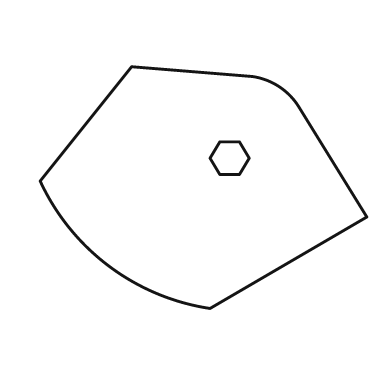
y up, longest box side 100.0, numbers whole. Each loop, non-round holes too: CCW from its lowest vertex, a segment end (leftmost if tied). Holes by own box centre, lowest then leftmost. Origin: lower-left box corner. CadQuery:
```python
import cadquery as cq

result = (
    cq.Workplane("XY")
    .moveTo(52.0, 0.0)
    .lineTo(100.0, 28.0)
    .lineTo(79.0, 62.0)
    .threePointArc((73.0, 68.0), (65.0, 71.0))
    .lineTo(28.0, 74.0)
    .lineTo(0.0, 39.0)
    .threePointArc((21.0, 13.0), (52.0, 0.0))
    .close()
    .moveTo(55.0, 41.0)
    .lineTo(61.0, 41.0)
    .lineTo(64.0, 46.0)
    .lineTo(61.0, 51.0)
    .lineTo(55.0, 51.0)
    .lineTo(52.0, 46.0)
    .close()
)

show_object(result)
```